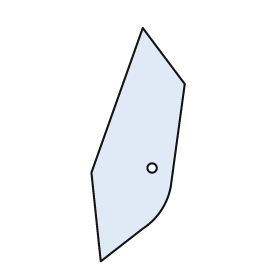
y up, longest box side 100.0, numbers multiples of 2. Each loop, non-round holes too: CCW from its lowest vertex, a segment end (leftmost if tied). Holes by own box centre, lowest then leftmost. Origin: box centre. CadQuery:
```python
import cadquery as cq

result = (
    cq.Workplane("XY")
    .moveTo(-16.0, -50.0)
    .lineTo(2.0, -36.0)
    .threePointArc((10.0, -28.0), (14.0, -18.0))
    .lineTo(20.0, 26.0)
    .lineTo(2.0, 50.0)
    .lineTo(-20.0, -12.0)
    .close()
    .moveTo(6.0, -10.0)
    .circle(2.0)
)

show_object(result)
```